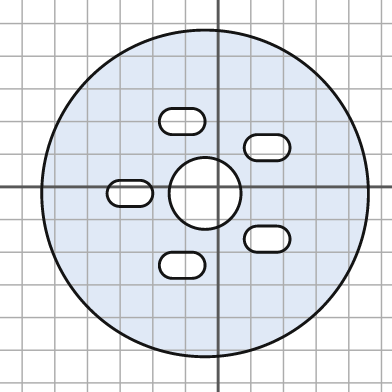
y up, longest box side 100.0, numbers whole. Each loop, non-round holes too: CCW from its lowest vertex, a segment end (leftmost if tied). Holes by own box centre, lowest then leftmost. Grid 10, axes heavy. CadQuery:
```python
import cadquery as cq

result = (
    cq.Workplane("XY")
    .moveTo(-4.0, -2.0)
    .circle(50.0)
    .moveTo(-14.0, -28.0)
    .lineTo(-8.0, -28.0)
    .threePointArc((-4.0, -24.0), (-8.0, -20.0))
    .lineTo(-14.0, -20.0)
    .threePointArc((-18.0, -24.0), (-14.0, -28.0))
    .close()
    .moveTo(12.0, -20.0)
    .lineTo(18.0, -20.0)
    .threePointArc((22.0, -16.0), (18.0, -12.0))
    .lineTo(12.0, -12.0)
    .threePointArc((8.0, -16.0), (12.0, -20.0))
    .close()
    .moveTo(-30.0, -6.0)
    .lineTo(-24.0, -6.0)
    .threePointArc((-20.0, -2.0), (-24.0, 2.0))
    .lineTo(-30.0, 2.0)
    .threePointArc((-34.0, -2.0), (-30.0, -6.0))
    .close()
    .moveTo(-4.0, -2.0)
    .circle(11.0)
    .moveTo(12.0, 8.0)
    .lineTo(18.0, 8.0)
    .threePointArc((22.0, 12.0), (18.0, 16.0))
    .lineTo(12.0, 16.0)
    .threePointArc((8.0, 12.0), (12.0, 8.0))
    .close()
    .moveTo(-14.0, 16.0)
    .lineTo(-8.0, 16.0)
    .threePointArc((-4.0, 20.0), (-8.0, 24.0))
    .lineTo(-14.0, 24.0)
    .threePointArc((-18.0, 20.0), (-14.0, 16.0))
    .close()
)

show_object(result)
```